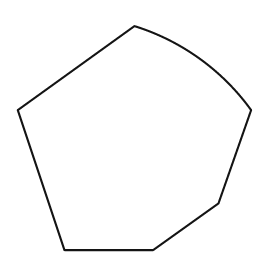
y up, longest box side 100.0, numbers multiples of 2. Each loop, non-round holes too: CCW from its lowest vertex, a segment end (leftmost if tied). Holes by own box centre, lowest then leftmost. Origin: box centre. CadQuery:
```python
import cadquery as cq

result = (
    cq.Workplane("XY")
    .moveTo(-30.0, -48.0)
    .lineTo(8.0, -48.0)
    .lineTo(36.0, -28.0)
    .lineTo(50.0, 12.0)
    .threePointArc((28.0, 34.0), (0.0, 48.0))
    .lineTo(-50.0, 12.0)
    .close()
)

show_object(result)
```